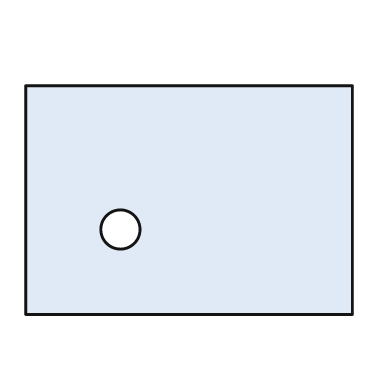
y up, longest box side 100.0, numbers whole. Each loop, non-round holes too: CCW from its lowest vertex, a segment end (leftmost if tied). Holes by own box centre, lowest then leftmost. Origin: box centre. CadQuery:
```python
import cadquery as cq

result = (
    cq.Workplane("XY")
    .moveTo(-50.0, -35.0)
    .lineTo(50.0, -35.0)
    .lineTo(50.0, 35.0)
    .lineTo(-50.0, 35.0)
    .close()
    .moveTo(-21.0, -9.0)
    .circle(6.0)
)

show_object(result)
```